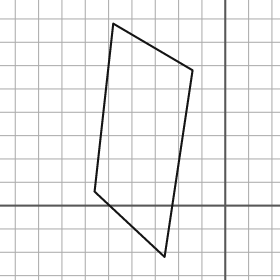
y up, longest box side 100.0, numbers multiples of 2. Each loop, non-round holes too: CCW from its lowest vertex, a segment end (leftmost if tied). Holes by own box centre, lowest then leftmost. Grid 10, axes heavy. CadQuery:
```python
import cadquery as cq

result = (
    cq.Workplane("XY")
    .moveTo(-26.0, -22.0)
    .lineTo(-14.0, 58.0)
    .lineTo(-48.0, 78.0)
    .lineTo(-56.0, 6.0)
    .close()
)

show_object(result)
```